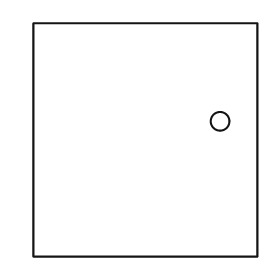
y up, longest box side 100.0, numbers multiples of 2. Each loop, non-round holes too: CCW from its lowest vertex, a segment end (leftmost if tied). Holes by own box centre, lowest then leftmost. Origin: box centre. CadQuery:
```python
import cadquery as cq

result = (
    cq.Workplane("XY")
    .moveTo(-48.0, -50.0)
    .lineTo(48.0, -50.0)
    .lineTo(48.0, 50.0)
    .lineTo(-48.0, 50.0)
    .close()
    .moveTo(32.0, 8.0)
    .circle(4.0)
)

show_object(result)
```